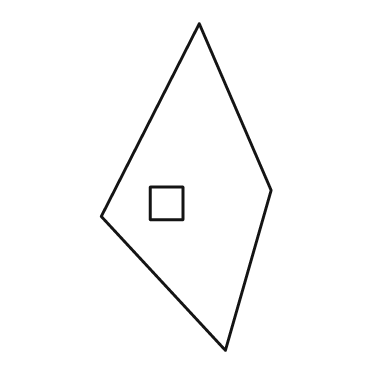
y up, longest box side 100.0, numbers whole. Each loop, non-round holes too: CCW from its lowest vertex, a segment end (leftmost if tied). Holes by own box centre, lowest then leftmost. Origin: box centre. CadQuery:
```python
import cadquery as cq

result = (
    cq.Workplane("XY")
    .moveTo(12.0, -50.0)
    .lineTo(26.0, -1.0)
    .lineTo(4.0, 50.0)
    .lineTo(-26.0, -9.0)
    .close()
    .moveTo(-11.0, -10.0)
    .lineTo(-1.0, -10.0)
    .lineTo(-1.0, 0.0)
    .lineTo(-11.0, 0.0)
    .close()
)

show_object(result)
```